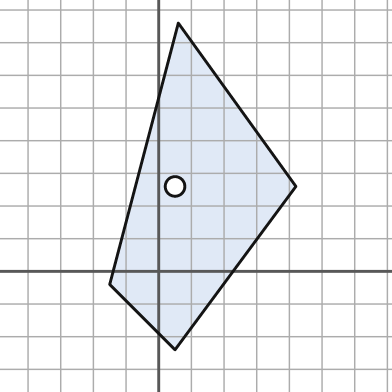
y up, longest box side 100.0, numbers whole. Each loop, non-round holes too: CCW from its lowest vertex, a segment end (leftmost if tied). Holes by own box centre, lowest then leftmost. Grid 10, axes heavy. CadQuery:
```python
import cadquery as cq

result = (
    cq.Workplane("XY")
    .moveTo(5.0, -24.0)
    .lineTo(42.0, 26.0)
    .lineTo(6.0, 76.0)
    .lineTo(-15.0, -4.0)
    .close()
    .moveTo(5.0, 26.0)
    .circle(3.0)
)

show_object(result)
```